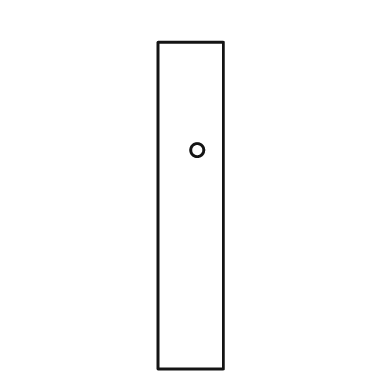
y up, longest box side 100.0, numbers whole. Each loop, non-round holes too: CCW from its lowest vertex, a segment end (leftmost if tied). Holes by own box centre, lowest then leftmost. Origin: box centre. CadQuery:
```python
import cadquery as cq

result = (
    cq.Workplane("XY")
    .moveTo(-10.0, -50.0)
    .lineTo(10.0, -50.0)
    .lineTo(10.0, 50.0)
    .lineTo(-10.0, 50.0)
    .close()
    .moveTo(2.0, 17.0)
    .circle(2.0)
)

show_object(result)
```